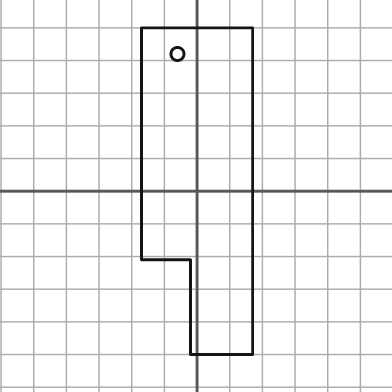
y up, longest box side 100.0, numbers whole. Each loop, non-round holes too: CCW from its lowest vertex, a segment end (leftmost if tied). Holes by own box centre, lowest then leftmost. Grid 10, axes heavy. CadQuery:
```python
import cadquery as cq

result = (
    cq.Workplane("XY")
    .moveTo(-2.0, -50.0)
    .lineTo(17.0, -50.0)
    .lineTo(17.0, 50.0)
    .lineTo(-17.0, 50.0)
    .lineTo(-17.0, -21.0)
    .lineTo(-2.0, -21.0)
    .close()
    .moveTo(-6.0, 42.0)
    .circle(2.0)
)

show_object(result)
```